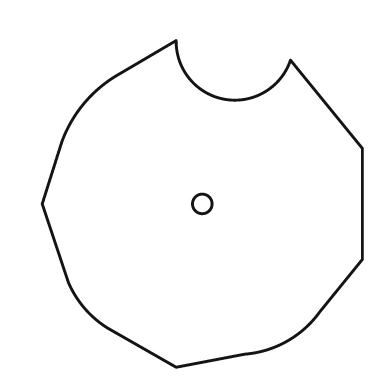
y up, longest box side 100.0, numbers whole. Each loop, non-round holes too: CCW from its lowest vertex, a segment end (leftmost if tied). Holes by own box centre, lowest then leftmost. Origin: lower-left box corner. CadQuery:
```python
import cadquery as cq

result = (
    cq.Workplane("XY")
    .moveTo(41.0, 0.0)
    .lineTo(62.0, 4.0)
    .threePointArc((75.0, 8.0), (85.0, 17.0))
    .lineTo(98.0, 33.0)
    .lineTo(98.0, 67.0)
    .lineTo(76.0, 94.0)
    .threePointArc((56.0, 82.0), (41.0, 100.0))
    .lineTo(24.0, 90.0)
    .threePointArc((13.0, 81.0), (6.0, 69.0))
    .lineTo(0.0, 50.0)
    .lineTo(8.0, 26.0)
    .threePointArc((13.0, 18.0), (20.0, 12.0))
    .close()
    .moveTo(49.0, 50.0)
    .circle(3.0)
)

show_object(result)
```